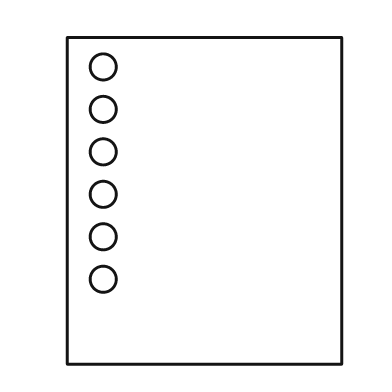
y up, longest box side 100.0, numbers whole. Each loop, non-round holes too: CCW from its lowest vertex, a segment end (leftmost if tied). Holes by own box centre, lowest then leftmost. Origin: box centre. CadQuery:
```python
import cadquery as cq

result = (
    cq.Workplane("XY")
    .moveTo(-42.0, -50.0)
    .lineTo(42.0, -50.0)
    .lineTo(42.0, 50.0)
    .lineTo(-42.0, 50.0)
    .close()
    .moveTo(-31.0, -24.0)
    .circle(4.0)
    .moveTo(-31.0, -11.0)
    .circle(4.0)
    .moveTo(-31.0, 2.0)
    .circle(4.0)
    .moveTo(-31.0, 15.0)
    .circle(4.0)
    .moveTo(-31.0, 28.0)
    .circle(4.0)
    .moveTo(-31.0, 41.0)
    .circle(4.0)
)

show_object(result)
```